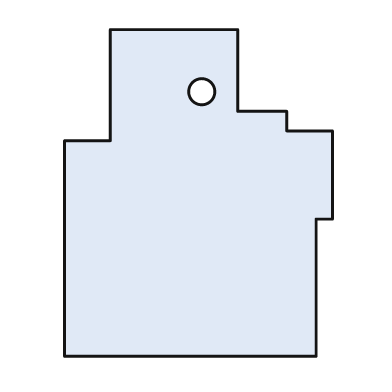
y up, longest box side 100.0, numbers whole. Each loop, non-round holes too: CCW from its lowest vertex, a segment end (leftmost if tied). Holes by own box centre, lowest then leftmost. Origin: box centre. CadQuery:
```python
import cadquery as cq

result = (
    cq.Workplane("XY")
    .moveTo(-41.0, -50.0)
    .lineTo(36.0, -50.0)
    .lineTo(36.0, -8.0)
    .lineTo(41.0, -8.0)
    .lineTo(41.0, 19.0)
    .lineTo(27.0, 19.0)
    .lineTo(27.0, 25.0)
    .lineTo(12.0, 25.0)
    .lineTo(12.0, 50.0)
    .lineTo(-27.0, 50.0)
    .lineTo(-27.0, 16.0)
    .lineTo(-41.0, 16.0)
    .close()
    .moveTo(1.0, 31.0)
    .circle(4.0)
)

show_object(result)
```